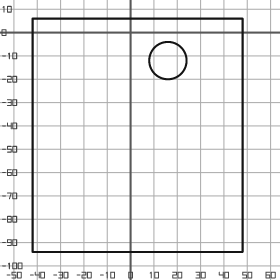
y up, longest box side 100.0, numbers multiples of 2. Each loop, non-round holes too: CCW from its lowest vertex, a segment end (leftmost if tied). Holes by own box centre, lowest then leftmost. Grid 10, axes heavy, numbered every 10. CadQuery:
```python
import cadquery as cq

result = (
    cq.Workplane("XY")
    .moveTo(-42.0, -94.0)
    .lineTo(48.0, -94.0)
    .lineTo(48.0, 6.0)
    .lineTo(-42.0, 6.0)
    .close()
    .moveTo(16.0, -12.0)
    .circle(8.0)
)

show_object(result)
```